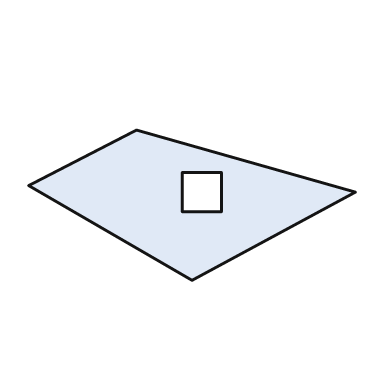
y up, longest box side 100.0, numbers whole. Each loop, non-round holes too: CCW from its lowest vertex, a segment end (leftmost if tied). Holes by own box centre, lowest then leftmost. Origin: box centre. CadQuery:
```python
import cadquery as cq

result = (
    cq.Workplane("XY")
    .moveTo(0.0, -23.0)
    .lineTo(50.0, 4.0)
    .lineTo(-17.0, 23.0)
    .lineTo(-50.0, 6.0)
    .close()
    .moveTo(-3.0, -2.0)
    .lineTo(9.0, -2.0)
    .lineTo(9.0, 10.0)
    .lineTo(-3.0, 10.0)
    .close()
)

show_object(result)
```